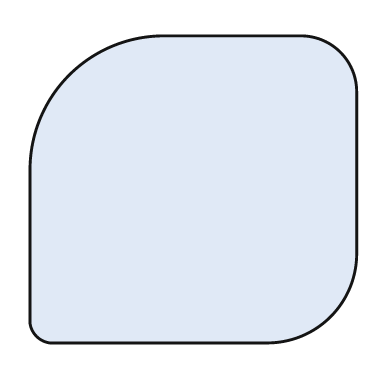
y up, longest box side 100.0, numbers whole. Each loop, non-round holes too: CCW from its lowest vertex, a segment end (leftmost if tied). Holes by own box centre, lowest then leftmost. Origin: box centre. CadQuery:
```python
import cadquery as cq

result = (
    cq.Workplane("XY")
    .moveTo(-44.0, -47.0)
    .lineTo(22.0, -47.0)
    .threePointArc((42.0, -39.0), (50.0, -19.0))
    .lineTo(50.0, 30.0)
    .threePointArc((45.0, 42.0), (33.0, 47.0))
    .lineTo(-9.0, 47.0)
    .threePointArc((-38.0, 35.0), (-50.0, 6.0))
    .lineTo(-50.0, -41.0)
    .threePointArc((-48.0, -45.0), (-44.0, -47.0))
    .close()
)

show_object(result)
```